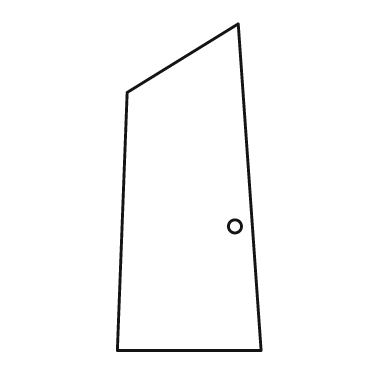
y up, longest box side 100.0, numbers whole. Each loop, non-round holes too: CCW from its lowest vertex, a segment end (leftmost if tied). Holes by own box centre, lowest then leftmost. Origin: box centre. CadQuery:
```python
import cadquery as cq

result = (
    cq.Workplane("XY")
    .moveTo(-22.0, -50.0)
    .lineTo(22.0, -50.0)
    .lineTo(15.0, 50.0)
    .lineTo(-19.0, 29.0)
    .close()
    .moveTo(14.0, -12.0)
    .circle(2.0)
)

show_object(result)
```